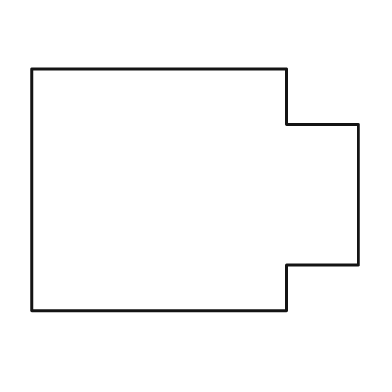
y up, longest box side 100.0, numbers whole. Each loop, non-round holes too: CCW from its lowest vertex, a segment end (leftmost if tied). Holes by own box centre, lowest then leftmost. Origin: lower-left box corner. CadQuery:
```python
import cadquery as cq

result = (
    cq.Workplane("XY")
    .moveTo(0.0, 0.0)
    .lineTo(78.0, 0.0)
    .lineTo(78.0, 14.0)
    .lineTo(100.0, 14.0)
    .lineTo(100.0, 57.0)
    .lineTo(78.0, 57.0)
    .lineTo(78.0, 74.0)
    .lineTo(0.0, 74.0)
    .close()
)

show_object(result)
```